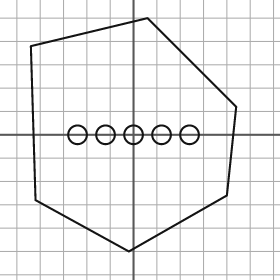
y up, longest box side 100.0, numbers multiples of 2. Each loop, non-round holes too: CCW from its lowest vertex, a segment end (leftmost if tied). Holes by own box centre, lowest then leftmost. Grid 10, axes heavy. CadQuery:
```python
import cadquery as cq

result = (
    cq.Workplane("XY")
    .moveTo(-2.0, -50.0)
    .lineTo(40.0, -26.0)
    .lineTo(44.0, 12.0)
    .lineTo(6.0, 50.0)
    .lineTo(-44.0, 38.0)
    .lineTo(-42.0, -28.0)
    .close()
    .moveTo(-24.0, 0.0)
    .circle(4.0)
    .moveTo(-12.0, 0.0)
    .circle(4.0)
    .moveTo(0.0, 0.0)
    .circle(4.0)
    .moveTo(12.0, 0.0)
    .circle(4.0)
    .moveTo(24.0, 0.0)
    .circle(4.0)
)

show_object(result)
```